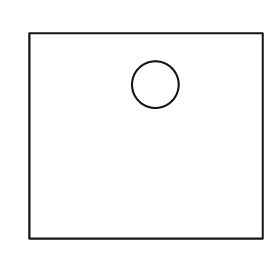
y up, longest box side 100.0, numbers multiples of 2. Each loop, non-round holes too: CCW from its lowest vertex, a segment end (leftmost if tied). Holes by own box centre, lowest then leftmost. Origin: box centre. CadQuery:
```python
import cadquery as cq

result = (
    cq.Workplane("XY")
    .moveTo(-50.0, -44.0)
    .lineTo(50.0, -44.0)
    .lineTo(50.0, 44.0)
    .lineTo(-50.0, 44.0)
    .close()
    .moveTo(4.0, 22.0)
    .circle(10.0)
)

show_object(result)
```